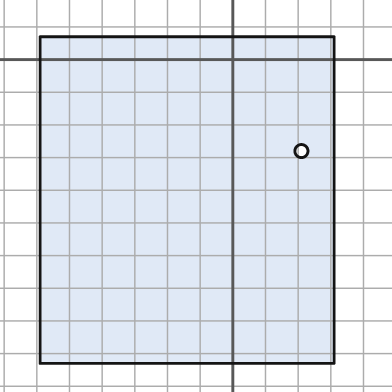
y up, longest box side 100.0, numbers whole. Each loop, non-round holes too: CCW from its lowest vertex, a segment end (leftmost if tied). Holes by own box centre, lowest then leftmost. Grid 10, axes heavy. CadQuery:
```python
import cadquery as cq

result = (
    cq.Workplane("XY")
    .moveTo(-59.0, -93.0)
    .lineTo(31.0, -93.0)
    .lineTo(31.0, 7.0)
    .lineTo(-59.0, 7.0)
    .close()
    .moveTo(21.0, -28.0)
    .circle(2.0)
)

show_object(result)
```